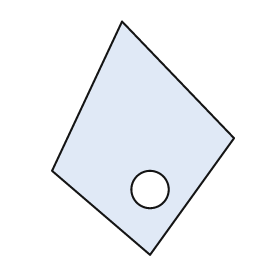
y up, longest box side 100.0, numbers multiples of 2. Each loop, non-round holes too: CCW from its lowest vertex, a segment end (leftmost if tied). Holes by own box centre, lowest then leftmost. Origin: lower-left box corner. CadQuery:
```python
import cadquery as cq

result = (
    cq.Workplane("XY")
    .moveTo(42.0, 0.0)
    .lineTo(78.0, 50.0)
    .lineTo(30.0, 100.0)
    .lineTo(0.0, 36.0)
    .close()
    .moveTo(42.0, 28.0)
    .circle(8.0)
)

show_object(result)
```